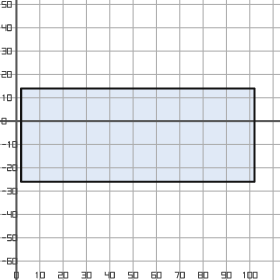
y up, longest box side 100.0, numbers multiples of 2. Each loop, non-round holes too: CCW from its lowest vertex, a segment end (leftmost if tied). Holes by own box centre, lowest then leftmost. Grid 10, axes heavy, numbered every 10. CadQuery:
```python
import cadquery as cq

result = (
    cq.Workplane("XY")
    .moveTo(2.0, -26.0)
    .lineTo(102.0, -26.0)
    .lineTo(102.0, 14.0)
    .lineTo(2.0, 14.0)
    .close()
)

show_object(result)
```